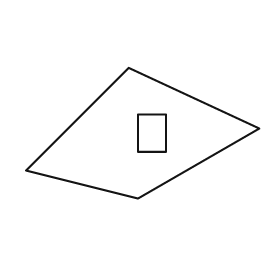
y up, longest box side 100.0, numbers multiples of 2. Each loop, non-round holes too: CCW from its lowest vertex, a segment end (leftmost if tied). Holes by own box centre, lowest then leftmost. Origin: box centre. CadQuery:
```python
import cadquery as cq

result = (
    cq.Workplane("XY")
    .moveTo(-2.0, -28.0)
    .lineTo(50.0, 2.0)
    .lineTo(-6.0, 28.0)
    .lineTo(-50.0, -16.0)
    .close()
    .moveTo(-2.0, -8.0)
    .lineTo(10.0, -8.0)
    .lineTo(10.0, 8.0)
    .lineTo(-2.0, 8.0)
    .close()
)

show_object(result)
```